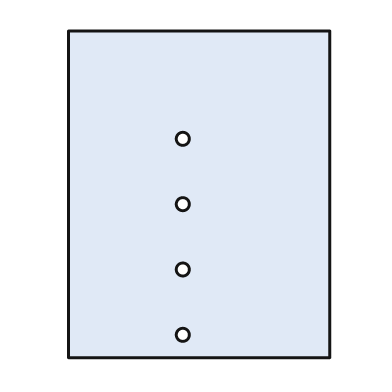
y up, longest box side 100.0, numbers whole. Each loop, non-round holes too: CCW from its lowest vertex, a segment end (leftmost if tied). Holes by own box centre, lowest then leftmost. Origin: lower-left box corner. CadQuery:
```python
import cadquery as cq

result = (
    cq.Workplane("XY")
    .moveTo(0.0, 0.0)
    .lineTo(80.0, 0.0)
    .lineTo(80.0, 100.0)
    .lineTo(0.0, 100.0)
    .close()
    .moveTo(35.0, 7.0)
    .circle(2.0)
    .moveTo(35.0, 27.0)
    .circle(2.0)
    .moveTo(35.0, 47.0)
    .circle(2.0)
    .moveTo(35.0, 67.0)
    .circle(2.0)
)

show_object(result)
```